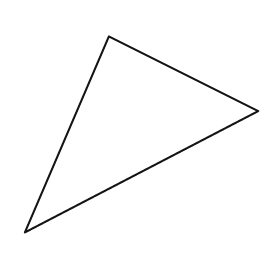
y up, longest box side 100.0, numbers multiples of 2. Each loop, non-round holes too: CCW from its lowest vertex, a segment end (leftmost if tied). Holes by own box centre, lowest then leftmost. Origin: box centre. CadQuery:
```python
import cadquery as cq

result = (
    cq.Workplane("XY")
    .moveTo(-50.0, -42.0)
    .lineTo(50.0, 10.0)
    .lineTo(-14.0, 42.0)
    .close()
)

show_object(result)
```